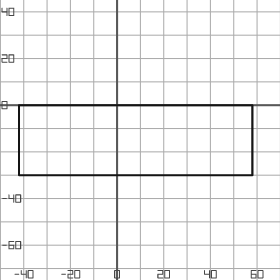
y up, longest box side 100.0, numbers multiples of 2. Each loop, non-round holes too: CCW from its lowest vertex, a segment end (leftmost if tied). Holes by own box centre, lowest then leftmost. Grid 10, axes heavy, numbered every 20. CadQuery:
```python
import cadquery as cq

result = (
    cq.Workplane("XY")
    .moveTo(-42.0, -30.0)
    .lineTo(58.0, -30.0)
    .lineTo(58.0, 0.0)
    .lineTo(-42.0, 0.0)
    .close()
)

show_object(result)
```